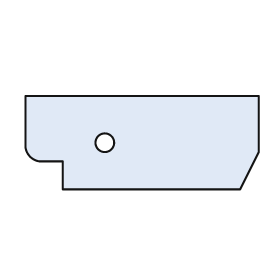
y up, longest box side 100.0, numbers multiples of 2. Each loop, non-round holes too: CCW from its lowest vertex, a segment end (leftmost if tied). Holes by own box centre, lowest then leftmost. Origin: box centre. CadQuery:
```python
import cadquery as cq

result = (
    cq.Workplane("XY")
    .moveTo(-34.0, -20.0)
    .lineTo(42.0, -20.0)
    .lineTo(50.0, -4.0)
    .lineTo(50.0, 20.0)
    .lineTo(-50.0, 20.0)
    .lineTo(-50.0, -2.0)
    .threePointArc((-48.0, -6.0), (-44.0, -8.0))
    .lineTo(-34.0, -8.0)
    .close()
    .moveTo(-16.0, 0.0)
    .circle(4.0)
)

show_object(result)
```